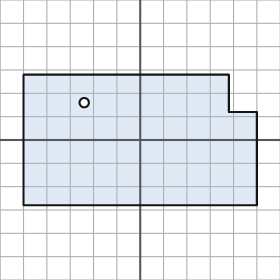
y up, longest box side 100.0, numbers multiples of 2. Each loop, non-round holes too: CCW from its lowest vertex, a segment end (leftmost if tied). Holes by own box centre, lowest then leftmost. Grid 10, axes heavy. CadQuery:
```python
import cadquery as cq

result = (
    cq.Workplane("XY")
    .moveTo(-50.0, -28.0)
    .lineTo(50.0, -28.0)
    .lineTo(50.0, 12.0)
    .lineTo(38.0, 12.0)
    .lineTo(38.0, 28.0)
    .lineTo(-50.0, 28.0)
    .close()
    .moveTo(-24.0, 16.0)
    .circle(2.0)
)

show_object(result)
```